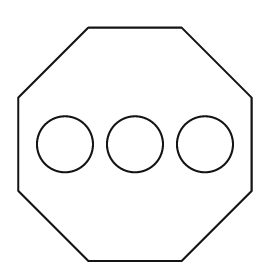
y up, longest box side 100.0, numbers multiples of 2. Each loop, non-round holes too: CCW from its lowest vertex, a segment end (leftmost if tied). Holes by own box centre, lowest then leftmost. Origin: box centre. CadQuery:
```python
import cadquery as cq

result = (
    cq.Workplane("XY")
    .moveTo(-20.0, -50.0)
    .lineTo(20.0, -50.0)
    .lineTo(50.0, -20.0)
    .lineTo(50.0, 20.0)
    .lineTo(20.0, 50.0)
    .lineTo(-20.0, 50.0)
    .lineTo(-50.0, 20.0)
    .lineTo(-50.0, -20.0)
    .close()
    .moveTo(-30.0, 0.0)
    .circle(12.0)
    .moveTo(0.0, 0.0)
    .circle(12.0)
    .moveTo(30.0, 0.0)
    .circle(12.0)
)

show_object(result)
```